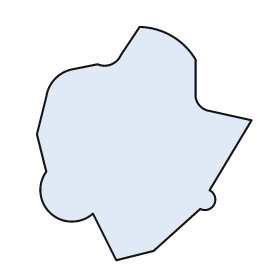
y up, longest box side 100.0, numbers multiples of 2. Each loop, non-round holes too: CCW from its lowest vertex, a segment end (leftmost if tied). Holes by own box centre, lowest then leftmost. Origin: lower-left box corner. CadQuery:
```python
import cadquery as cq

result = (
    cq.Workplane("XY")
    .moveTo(34.0, 0.0)
    .lineTo(50.0, 4.0)
    .lineTo(70.0, 22.0)
    .threePointArc((76.0, 24.0), (74.0, 30.0))
    .lineTo(92.0, 60.0)
    .lineTo(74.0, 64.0)
    .threePointArc((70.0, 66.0), (68.0, 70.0))
    .lineTo(68.0, 86.0)
    .threePointArc((58.0, 96.0), (44.0, 100.0))
    .lineTo(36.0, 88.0)
    .threePointArc((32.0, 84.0), (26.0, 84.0))
    .lineTo(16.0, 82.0)
    .threePointArc((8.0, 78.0), (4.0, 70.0))
    .lineTo(0.0, 54.0)
    .lineTo(4.0, 38.0)
    .threePointArc((6.0, 20.0), (24.0, 20.0))
    .close()
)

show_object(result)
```